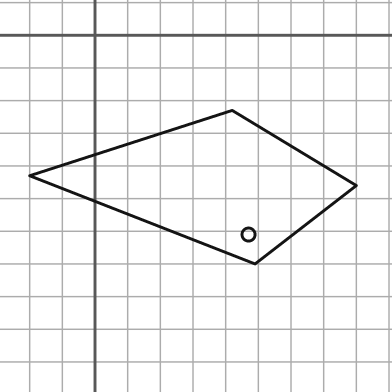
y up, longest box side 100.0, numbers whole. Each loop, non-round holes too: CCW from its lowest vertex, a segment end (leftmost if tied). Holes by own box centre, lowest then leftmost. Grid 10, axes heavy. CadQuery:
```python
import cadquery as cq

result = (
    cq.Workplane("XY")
    .moveTo(49.0, -70.0)
    .lineTo(80.0, -46.0)
    .lineTo(42.0, -23.0)
    .lineTo(-20.0, -43.0)
    .close()
    .moveTo(47.0, -61.0)
    .circle(2.0)
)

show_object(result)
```